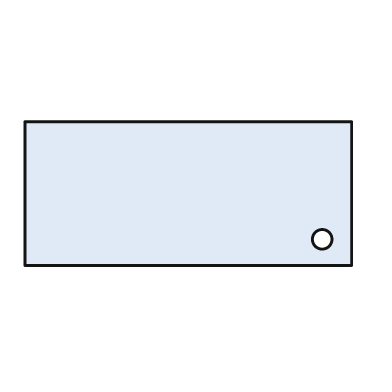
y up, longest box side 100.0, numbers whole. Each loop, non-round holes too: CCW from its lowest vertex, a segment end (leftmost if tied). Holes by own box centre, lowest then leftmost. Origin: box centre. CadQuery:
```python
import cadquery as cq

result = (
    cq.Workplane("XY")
    .moveTo(-50.0, -22.0)
    .lineTo(50.0, -22.0)
    .lineTo(50.0, 22.0)
    .lineTo(-50.0, 22.0)
    .close()
    .moveTo(41.0, -14.0)
    .circle(3.0)
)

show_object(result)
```